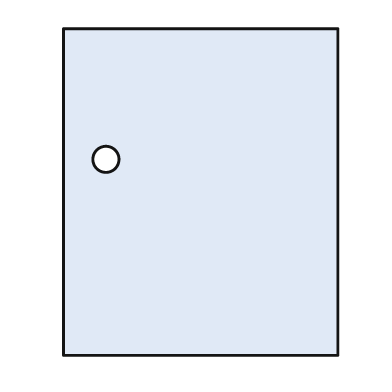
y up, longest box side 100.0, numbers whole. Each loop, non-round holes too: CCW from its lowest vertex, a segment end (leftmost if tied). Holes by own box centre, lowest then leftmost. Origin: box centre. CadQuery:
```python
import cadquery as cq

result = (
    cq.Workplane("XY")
    .moveTo(-42.0, -50.0)
    .lineTo(42.0, -50.0)
    .lineTo(42.0, 50.0)
    .lineTo(-42.0, 50.0)
    .close()
    .moveTo(-29.0, 10.0)
    .circle(4.0)
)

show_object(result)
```